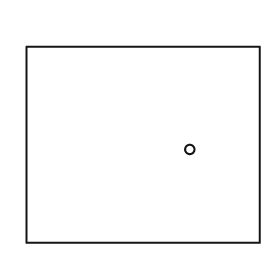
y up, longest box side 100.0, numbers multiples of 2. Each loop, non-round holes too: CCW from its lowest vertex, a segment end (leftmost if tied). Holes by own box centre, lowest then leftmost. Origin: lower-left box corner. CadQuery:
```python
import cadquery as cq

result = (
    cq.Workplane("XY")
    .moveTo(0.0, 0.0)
    .lineTo(100.0, 0.0)
    .lineTo(100.0, 84.0)
    .lineTo(0.0, 84.0)
    .close()
    .moveTo(70.0, 40.0)
    .circle(2.0)
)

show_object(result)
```